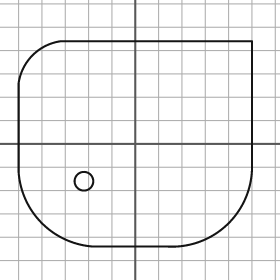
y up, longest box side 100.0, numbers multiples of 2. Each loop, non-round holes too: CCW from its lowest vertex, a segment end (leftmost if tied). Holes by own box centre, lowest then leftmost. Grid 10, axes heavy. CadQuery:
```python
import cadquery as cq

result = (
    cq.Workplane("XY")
    .moveTo(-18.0, -44.0)
    .lineTo(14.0, -44.0)
    .threePointArc((40.0, -34.0), (50.0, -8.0))
    .lineTo(50.0, 44.0)
    .lineTo(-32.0, 44.0)
    .threePointArc((-44.0, 38.0), (-50.0, 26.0))
    .lineTo(-50.0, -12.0)
    .threePointArc((-40.0, -34.0), (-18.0, -44.0))
    .close()
    .moveTo(-22.0, -16.0)
    .circle(4.0)
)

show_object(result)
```